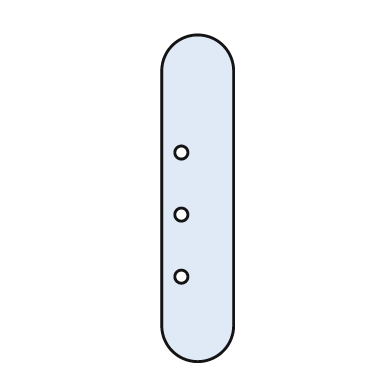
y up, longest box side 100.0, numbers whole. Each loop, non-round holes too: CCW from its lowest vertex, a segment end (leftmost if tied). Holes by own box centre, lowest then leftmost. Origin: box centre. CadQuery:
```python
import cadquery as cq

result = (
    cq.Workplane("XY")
    .moveTo(-11.0, -39.0)
    .threePointArc((0.0, -50.0), (11.0, -39.0))
    .lineTo(11.0, 39.0)
    .threePointArc((0.0, 50.0), (-11.0, 39.0))
    .close()
    .moveTo(-5.0, -24.0)
    .circle(2.0)
    .moveTo(-5.0, -5.0)
    .circle(2.0)
    .moveTo(-5.0, 14.0)
    .circle(2.0)
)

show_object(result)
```